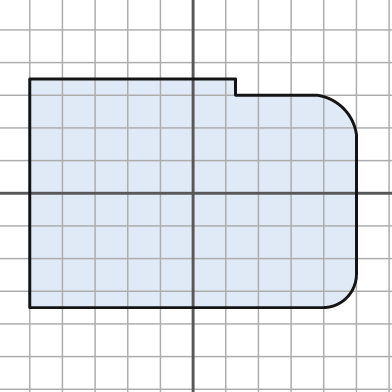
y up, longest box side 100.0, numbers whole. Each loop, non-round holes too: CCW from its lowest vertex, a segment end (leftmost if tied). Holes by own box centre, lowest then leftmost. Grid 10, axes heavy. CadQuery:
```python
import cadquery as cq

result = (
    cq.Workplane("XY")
    .moveTo(-50.0, -35.0)
    .lineTo(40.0, -35.0)
    .threePointArc((47.0, -32.0), (50.0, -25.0))
    .lineTo(50.0, 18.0)
    .threePointArc((46.0, 26.0), (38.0, 30.0))
    .lineTo(13.0, 30.0)
    .lineTo(13.0, 35.0)
    .lineTo(-50.0, 35.0)
    .close()
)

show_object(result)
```